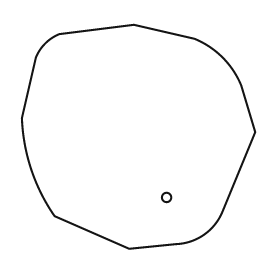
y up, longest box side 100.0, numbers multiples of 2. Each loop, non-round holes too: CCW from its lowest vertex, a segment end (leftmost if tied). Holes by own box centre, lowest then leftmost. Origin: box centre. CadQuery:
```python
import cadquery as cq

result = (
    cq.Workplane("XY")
    .moveTo(-4.0, -48.0)
    .lineTo(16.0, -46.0)
    .threePointArc((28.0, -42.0), (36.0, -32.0))
    .lineTo(50.0, 2.0)
    .lineTo(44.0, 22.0)
    .threePointArc((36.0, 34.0), (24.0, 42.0))
    .lineTo(-2.0, 48.0)
    .lineTo(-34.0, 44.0)
    .threePointArc((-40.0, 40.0), (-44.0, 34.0))
    .lineTo(-50.0, 8.0)
    .threePointArc((-46.0, -14.0), (-36.0, -34.0))
    .close()
    .moveTo(12.0, -26.0)
    .circle(2.0)
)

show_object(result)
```